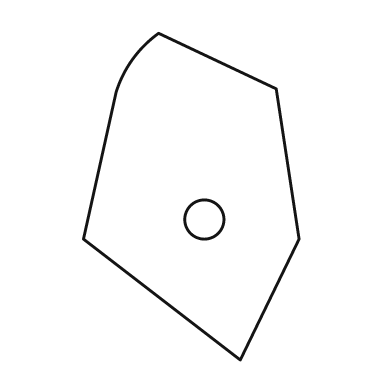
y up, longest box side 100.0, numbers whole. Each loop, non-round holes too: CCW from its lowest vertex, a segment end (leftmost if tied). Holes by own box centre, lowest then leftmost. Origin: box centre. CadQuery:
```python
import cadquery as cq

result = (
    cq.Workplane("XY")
    .moveTo(15.0, -50.0)
    .lineTo(33.0, -13.0)
    .lineTo(26.0, 33.0)
    .lineTo(-10.0, 50.0)
    .threePointArc((-18.0, 42.0), (-23.0, 32.0))
    .lineTo(-33.0, -13.0)
    .close()
    .moveTo(4.0, -7.0)
    .circle(6.0)
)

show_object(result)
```